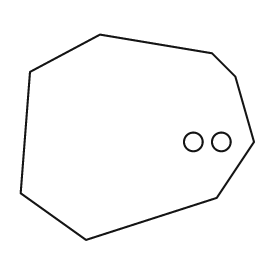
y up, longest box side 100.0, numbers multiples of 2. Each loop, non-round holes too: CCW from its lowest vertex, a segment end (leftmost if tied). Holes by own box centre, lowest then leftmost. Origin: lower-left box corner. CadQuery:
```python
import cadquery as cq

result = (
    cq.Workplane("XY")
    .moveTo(28.0, 0.0)
    .lineTo(84.0, 18.0)
    .lineTo(100.0, 42.0)
    .lineTo(92.0, 70.0)
    .lineTo(82.0, 80.0)
    .lineTo(34.0, 88.0)
    .lineTo(4.0, 72.0)
    .lineTo(0.0, 20.0)
    .close()
    .moveTo(74.0, 42.0)
    .circle(4.0)
    .moveTo(86.0, 42.0)
    .circle(4.0)
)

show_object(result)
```